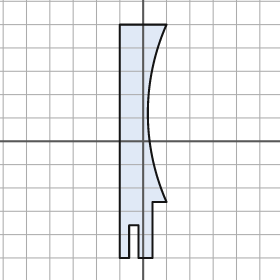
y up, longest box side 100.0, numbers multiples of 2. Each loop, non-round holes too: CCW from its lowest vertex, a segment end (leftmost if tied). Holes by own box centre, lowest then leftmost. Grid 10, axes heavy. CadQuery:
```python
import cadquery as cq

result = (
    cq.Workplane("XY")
    .moveTo(-10.0, -50.0)
    .lineTo(-6.0, -50.0)
    .lineTo(-6.0, -36.0)
    .lineTo(-2.0, -36.0)
    .lineTo(-2.0, -50.0)
    .lineTo(4.0, -50.0)
    .lineTo(4.0, -26.0)
    .lineTo(10.0, -26.0)
    .threePointArc((2.0, 12.0), (10.0, 50.0))
    .lineTo(-10.0, 50.0)
    .close()
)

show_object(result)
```